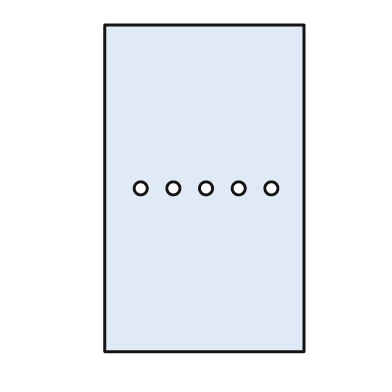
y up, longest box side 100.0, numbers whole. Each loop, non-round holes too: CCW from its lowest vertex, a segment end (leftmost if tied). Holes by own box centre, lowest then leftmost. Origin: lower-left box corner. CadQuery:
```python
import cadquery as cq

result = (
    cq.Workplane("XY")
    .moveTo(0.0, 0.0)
    .lineTo(61.0, 0.0)
    .lineTo(61.0, 100.0)
    .lineTo(0.0, 100.0)
    .close()
    .moveTo(11.0, 50.0)
    .circle(2.0)
    .moveTo(21.0, 50.0)
    .circle(2.0)
    .moveTo(31.0, 50.0)
    .circle(2.0)
    .moveTo(41.0, 50.0)
    .circle(2.0)
    .moveTo(51.0, 50.0)
    .circle(2.0)
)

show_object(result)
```